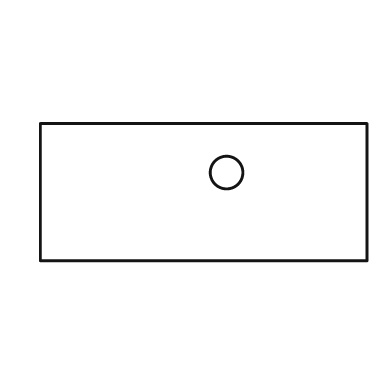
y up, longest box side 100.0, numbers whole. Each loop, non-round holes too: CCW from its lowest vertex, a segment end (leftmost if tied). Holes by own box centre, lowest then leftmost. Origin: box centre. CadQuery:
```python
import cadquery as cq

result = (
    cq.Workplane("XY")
    .moveTo(-50.0, -21.0)
    .lineTo(50.0, -21.0)
    .lineTo(50.0, 21.0)
    .lineTo(-50.0, 21.0)
    .close()
    .moveTo(7.0, 6.0)
    .circle(5.0)
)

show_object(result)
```